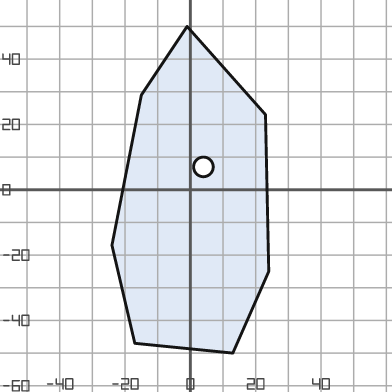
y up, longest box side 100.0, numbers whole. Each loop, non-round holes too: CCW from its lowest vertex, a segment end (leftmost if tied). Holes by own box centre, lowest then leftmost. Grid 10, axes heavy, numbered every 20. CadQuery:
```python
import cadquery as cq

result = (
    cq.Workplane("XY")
    .moveTo(13.0, -50.0)
    .lineTo(24.0, -25.0)
    .lineTo(23.0, 23.0)
    .lineTo(-1.0, 50.0)
    .lineTo(-15.0, 29.0)
    .lineTo(-24.0, -17.0)
    .lineTo(-17.0, -47.0)
    .close()
    .moveTo(4.0, 7.0)
    .circle(3.0)
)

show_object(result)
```